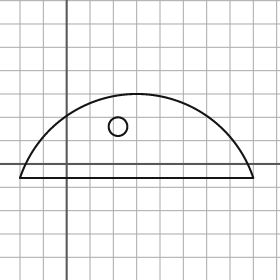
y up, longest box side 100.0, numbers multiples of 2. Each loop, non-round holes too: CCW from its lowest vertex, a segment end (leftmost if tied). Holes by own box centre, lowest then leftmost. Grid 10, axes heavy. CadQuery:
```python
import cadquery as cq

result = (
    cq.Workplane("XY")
    .moveTo(-20.0, -6.0)
    .lineTo(80.0, -6.0)
    .threePointArc((30.0, 30.0), (-20.0, -6.0))
    .close()
    .moveTo(22.0, 16.0)
    .circle(4.0)
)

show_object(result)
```